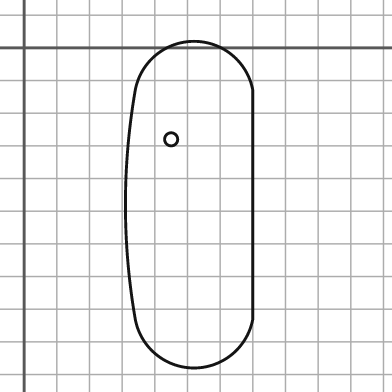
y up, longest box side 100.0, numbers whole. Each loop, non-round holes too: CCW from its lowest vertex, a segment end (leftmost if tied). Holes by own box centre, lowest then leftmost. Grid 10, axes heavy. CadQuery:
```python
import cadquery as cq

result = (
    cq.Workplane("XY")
    .moveTo(34.0, -83.0)
    .threePointArc((52.0, -98.0), (70.0, -83.0))
    .lineTo(70.0, -13.0)
    .threePointArc((52.0, 2.0), (34.0, -13.0))
    .threePointArc((31.0, -48.0), (34.0, -83.0))
    .close()
    .moveTo(45.0, -28.0)
    .circle(2.0)
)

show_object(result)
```